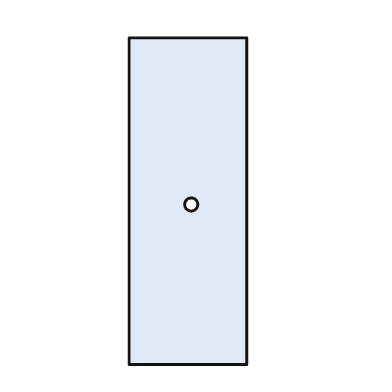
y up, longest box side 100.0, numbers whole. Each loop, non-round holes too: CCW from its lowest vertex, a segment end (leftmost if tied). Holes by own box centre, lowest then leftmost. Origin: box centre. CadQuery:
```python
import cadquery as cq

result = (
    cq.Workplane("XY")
    .moveTo(-18.0, -50.0)
    .lineTo(18.0, -50.0)
    .lineTo(18.0, 50.0)
    .lineTo(-18.0, 50.0)
    .close()
    .moveTo(1.0, -1.0)
    .circle(2.0)
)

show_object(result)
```